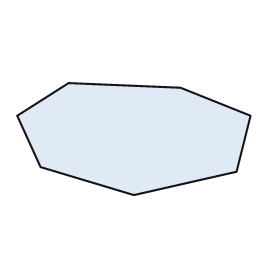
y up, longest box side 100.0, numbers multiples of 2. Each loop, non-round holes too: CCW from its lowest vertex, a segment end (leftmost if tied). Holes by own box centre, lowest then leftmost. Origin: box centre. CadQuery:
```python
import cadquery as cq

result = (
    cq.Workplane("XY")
    .moveTo(0.0, -24.0)
    .lineTo(44.0, -14.0)
    .lineTo(50.0, 10.0)
    .lineTo(20.0, 22.0)
    .lineTo(-28.0, 24.0)
    .lineTo(-50.0, 10.0)
    .lineTo(-40.0, -12.0)
    .close()
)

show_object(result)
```